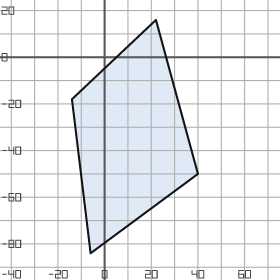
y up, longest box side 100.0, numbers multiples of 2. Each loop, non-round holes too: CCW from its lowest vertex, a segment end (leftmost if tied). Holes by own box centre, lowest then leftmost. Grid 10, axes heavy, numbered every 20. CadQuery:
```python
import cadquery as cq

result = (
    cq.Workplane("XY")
    .moveTo(-6.0, -84.0)
    .lineTo(40.0, -50.0)
    .lineTo(22.0, 16.0)
    .lineTo(-14.0, -18.0)
    .close()
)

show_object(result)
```